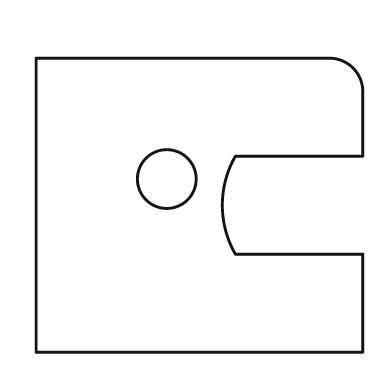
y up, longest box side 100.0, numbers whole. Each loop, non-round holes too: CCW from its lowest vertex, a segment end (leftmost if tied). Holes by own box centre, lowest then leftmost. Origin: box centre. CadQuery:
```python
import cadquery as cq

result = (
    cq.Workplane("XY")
    .moveTo(-50.0, -45.0)
    .lineTo(50.0, -45.0)
    .lineTo(50.0, -15.0)
    .lineTo(11.0, -15.0)
    .threePointArc((7.0, 0.0), (11.0, 15.0))
    .lineTo(50.0, 15.0)
    .lineTo(50.0, 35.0)
    .threePointArc((47.0, 42.0), (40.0, 45.0))
    .lineTo(-50.0, 45.0)
    .close()
    .moveTo(-10.0, 8.0)
    .circle(9.0)
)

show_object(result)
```